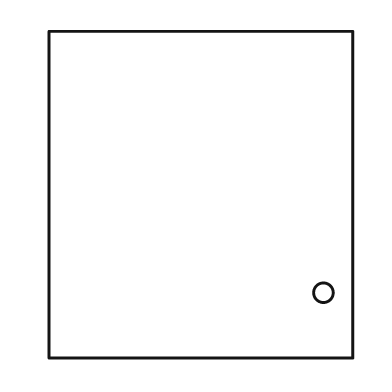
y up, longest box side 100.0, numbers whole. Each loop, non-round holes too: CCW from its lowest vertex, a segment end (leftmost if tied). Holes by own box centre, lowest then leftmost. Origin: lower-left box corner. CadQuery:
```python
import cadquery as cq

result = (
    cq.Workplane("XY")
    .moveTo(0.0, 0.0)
    .lineTo(93.0, 0.0)
    .lineTo(93.0, 100.0)
    .lineTo(0.0, 100.0)
    .close()
    .moveTo(84.0, 20.0)
    .circle(3.0)
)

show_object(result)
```